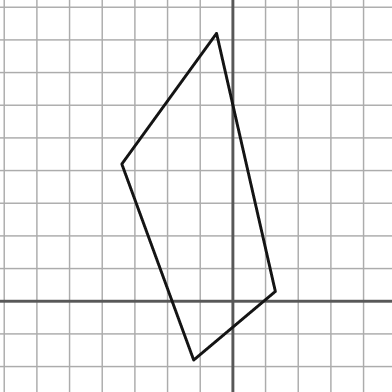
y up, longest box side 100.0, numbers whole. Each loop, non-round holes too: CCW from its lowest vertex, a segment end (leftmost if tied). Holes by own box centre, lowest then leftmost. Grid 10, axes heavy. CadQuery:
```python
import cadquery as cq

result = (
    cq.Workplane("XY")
    .moveTo(-12.0, -18.0)
    .lineTo(13.0, 3.0)
    .lineTo(-5.0, 82.0)
    .lineTo(-34.0, 42.0)
    .close()
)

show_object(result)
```